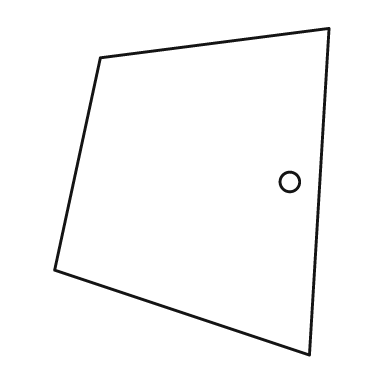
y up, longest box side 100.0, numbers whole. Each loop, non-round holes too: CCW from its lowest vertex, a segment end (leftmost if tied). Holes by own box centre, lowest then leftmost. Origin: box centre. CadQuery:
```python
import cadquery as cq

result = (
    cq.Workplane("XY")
    .moveTo(36.0, -50.0)
    .lineTo(42.0, 50.0)
    .lineTo(-28.0, 41.0)
    .lineTo(-42.0, -24.0)
    .close()
    .moveTo(30.0, 3.0)
    .circle(3.0)
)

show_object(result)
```